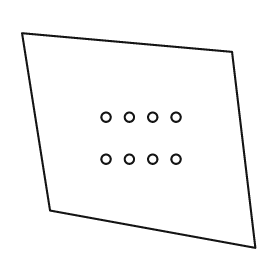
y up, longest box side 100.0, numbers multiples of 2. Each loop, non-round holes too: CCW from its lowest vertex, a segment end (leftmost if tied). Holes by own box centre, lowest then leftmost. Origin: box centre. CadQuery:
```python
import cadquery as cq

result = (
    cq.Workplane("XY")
    .moveTo(50.0, -46.0)
    .lineTo(40.0, 38.0)
    .lineTo(-50.0, 46.0)
    .lineTo(-38.0, -30.0)
    .close()
    .moveTo(-14.0, -8.0)
    .circle(2.0)
    .moveTo(-4.0, -8.0)
    .circle(2.0)
    .moveTo(6.0, -8.0)
    .circle(2.0)
    .moveTo(16.0, -8.0)
    .circle(2.0)
    .moveTo(-14.0, 10.0)
    .circle(2.0)
    .moveTo(-4.0, 10.0)
    .circle(2.0)
    .moveTo(6.0, 10.0)
    .circle(2.0)
    .moveTo(16.0, 10.0)
    .circle(2.0)
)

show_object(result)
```